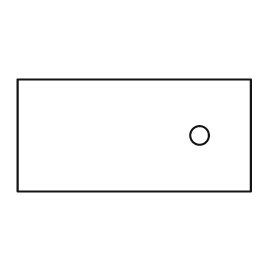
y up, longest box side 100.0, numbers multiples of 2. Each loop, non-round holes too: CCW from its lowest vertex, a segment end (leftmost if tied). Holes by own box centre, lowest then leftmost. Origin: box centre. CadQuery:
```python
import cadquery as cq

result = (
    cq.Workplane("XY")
    .moveTo(-50.0, -24.0)
    .lineTo(50.0, -24.0)
    .lineTo(50.0, 24.0)
    .lineTo(-50.0, 24.0)
    .close()
    .moveTo(28.0, 0.0)
    .circle(4.0)
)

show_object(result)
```